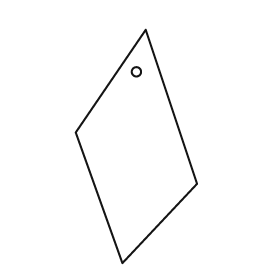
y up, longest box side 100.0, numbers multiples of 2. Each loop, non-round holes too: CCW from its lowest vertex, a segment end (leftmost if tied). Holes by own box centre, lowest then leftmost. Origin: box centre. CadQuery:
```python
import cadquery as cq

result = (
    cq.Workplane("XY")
    .moveTo(-6.0, -50.0)
    .lineTo(26.0, -16.0)
    .lineTo(4.0, 50.0)
    .lineTo(-26.0, 6.0)
    .close()
    .moveTo(0.0, 32.0)
    .circle(2.0)
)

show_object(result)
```